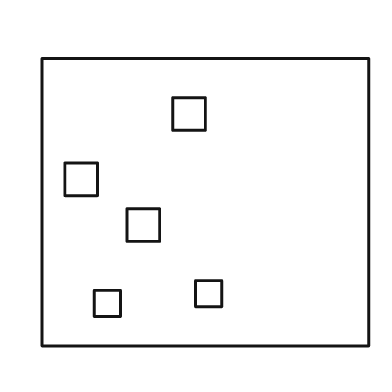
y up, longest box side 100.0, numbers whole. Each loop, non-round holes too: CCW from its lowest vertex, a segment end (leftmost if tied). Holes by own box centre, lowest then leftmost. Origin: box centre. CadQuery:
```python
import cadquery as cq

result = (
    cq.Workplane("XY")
    .moveTo(-50.0, -44.0)
    .lineTo(50.0, -44.0)
    .lineTo(50.0, 44.0)
    .lineTo(-50.0, 44.0)
    .close()
    .moveTo(-34.0, -35.0)
    .lineTo(-26.0, -35.0)
    .lineTo(-26.0, -27.0)
    .lineTo(-34.0, -27.0)
    .close()
    .moveTo(-3.0, -32.0)
    .lineTo(5.0, -32.0)
    .lineTo(5.0, -24.0)
    .lineTo(-3.0, -24.0)
    .close()
    .moveTo(-24.0, -12.0)
    .lineTo(-14.0, -12.0)
    .lineTo(-14.0, -2.0)
    .lineTo(-24.0, -2.0)
    .close()
    .moveTo(-43.0, 2.0)
    .lineTo(-33.0, 2.0)
    .lineTo(-33.0, 12.0)
    .lineTo(-43.0, 12.0)
    .close()
    .moveTo(-10.0, 22.0)
    .lineTo(0.0, 22.0)
    .lineTo(0.0, 32.0)
    .lineTo(-10.0, 32.0)
    .close()
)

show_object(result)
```